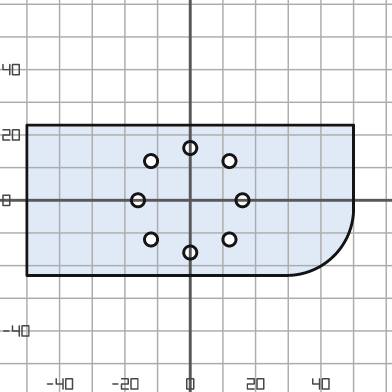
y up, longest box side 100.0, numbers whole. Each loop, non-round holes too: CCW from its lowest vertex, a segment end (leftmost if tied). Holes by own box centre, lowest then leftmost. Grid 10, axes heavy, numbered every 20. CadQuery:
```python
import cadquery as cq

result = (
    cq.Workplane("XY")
    .moveTo(-50.0, -23.0)
    .lineTo(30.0, -23.0)
    .threePointArc((44.0, -17.0), (50.0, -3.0))
    .lineTo(50.0, 23.0)
    .lineTo(-50.0, 23.0)
    .close()
    .moveTo(0.0, -16.0)
    .circle(2.0)
    .moveTo(-12.0, -12.0)
    .circle(2.0)
    .moveTo(12.0, -12.0)
    .circle(2.0)
    .moveTo(-16.0, 0.0)
    .circle(2.0)
    .moveTo(16.0, 0.0)
    .circle(2.0)
    .moveTo(-12.0, 12.0)
    .circle(2.0)
    .moveTo(12.0, 12.0)
    .circle(2.0)
    .moveTo(0.0, 16.0)
    .circle(2.0)
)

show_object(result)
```